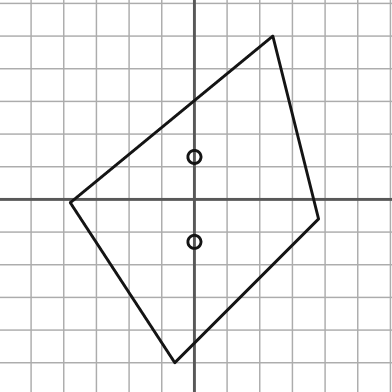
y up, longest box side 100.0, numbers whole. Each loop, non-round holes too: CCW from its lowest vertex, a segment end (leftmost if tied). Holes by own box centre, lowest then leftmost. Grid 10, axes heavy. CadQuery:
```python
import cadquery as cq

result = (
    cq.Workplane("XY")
    .moveTo(-6.0, -50.0)
    .lineTo(38.0, -6.0)
    .lineTo(24.0, 50.0)
    .lineTo(-38.0, -1.0)
    .close()
    .moveTo(0.0, -13.0)
    .circle(2.0)
    .moveTo(0.0, 13.0)
    .circle(2.0)
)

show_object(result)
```